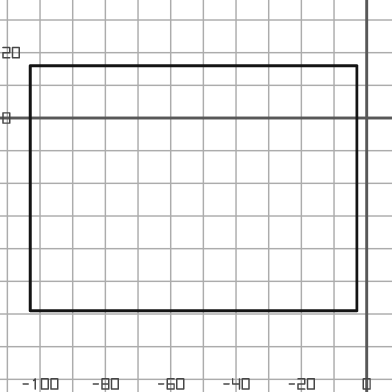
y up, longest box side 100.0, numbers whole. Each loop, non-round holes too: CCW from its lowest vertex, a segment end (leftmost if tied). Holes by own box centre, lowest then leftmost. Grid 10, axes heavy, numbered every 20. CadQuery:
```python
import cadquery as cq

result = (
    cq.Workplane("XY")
    .moveTo(-103.0, -59.0)
    .lineTo(-3.0, -59.0)
    .lineTo(-3.0, 16.0)
    .lineTo(-103.0, 16.0)
    .close()
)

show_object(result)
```